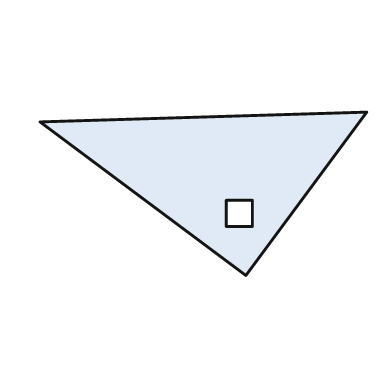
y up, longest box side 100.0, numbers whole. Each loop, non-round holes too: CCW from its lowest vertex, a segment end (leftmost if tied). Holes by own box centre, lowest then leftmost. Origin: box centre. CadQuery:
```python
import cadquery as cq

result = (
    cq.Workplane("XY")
    .moveTo(13.0, -25.0)
    .lineTo(50.0, 25.0)
    .lineTo(-50.0, 22.0)
    .close()
    .moveTo(7.0, -10.0)
    .lineTo(15.0, -10.0)
    .lineTo(15.0, -2.0)
    .lineTo(7.0, -2.0)
    .close()
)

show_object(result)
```